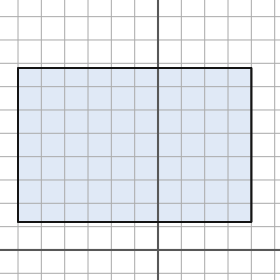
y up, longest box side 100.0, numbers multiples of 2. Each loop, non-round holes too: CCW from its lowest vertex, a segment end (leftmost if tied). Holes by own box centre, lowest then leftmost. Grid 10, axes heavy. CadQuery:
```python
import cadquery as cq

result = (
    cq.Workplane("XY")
    .moveTo(-60.0, 12.0)
    .lineTo(40.0, 12.0)
    .lineTo(40.0, 78.0)
    .lineTo(-60.0, 78.0)
    .close()
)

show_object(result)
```